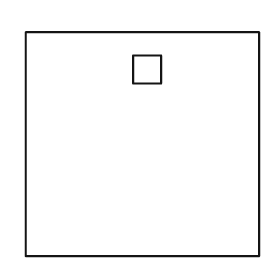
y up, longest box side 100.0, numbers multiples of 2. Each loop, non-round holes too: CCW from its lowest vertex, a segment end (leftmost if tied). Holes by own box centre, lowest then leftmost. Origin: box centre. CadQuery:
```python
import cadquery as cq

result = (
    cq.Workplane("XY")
    .moveTo(-50.0, -48.0)
    .lineTo(50.0, -48.0)
    .lineTo(50.0, 48.0)
    .lineTo(-50.0, 48.0)
    .close()
    .moveTo(-4.0, 26.0)
    .lineTo(8.0, 26.0)
    .lineTo(8.0, 38.0)
    .lineTo(-4.0, 38.0)
    .close()
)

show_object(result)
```